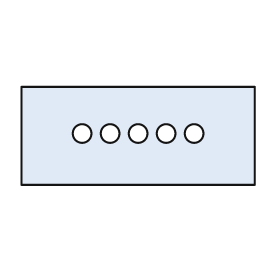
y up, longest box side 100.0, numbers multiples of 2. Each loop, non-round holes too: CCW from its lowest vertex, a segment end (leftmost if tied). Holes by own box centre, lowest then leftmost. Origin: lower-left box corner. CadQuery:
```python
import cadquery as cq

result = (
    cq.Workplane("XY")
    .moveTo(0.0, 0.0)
    .lineTo(100.0, 0.0)
    .lineTo(100.0, 42.0)
    .lineTo(0.0, 42.0)
    .close()
    .moveTo(26.0, 22.0)
    .circle(4.0)
    .moveTo(38.0, 22.0)
    .circle(4.0)
    .moveTo(50.0, 22.0)
    .circle(4.0)
    .moveTo(62.0, 22.0)
    .circle(4.0)
    .moveTo(74.0, 22.0)
    .circle(4.0)
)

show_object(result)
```